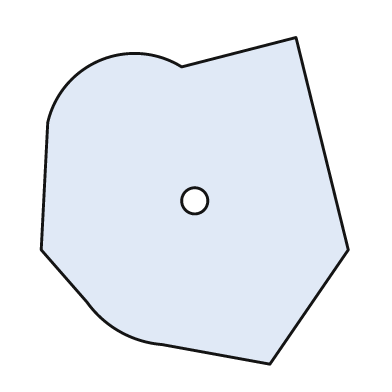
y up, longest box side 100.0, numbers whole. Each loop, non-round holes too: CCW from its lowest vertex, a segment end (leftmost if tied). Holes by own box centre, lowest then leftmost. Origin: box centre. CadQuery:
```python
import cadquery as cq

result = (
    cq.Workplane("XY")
    .moveTo(23.0, -50.0)
    .lineTo(47.0, -15.0)
    .lineTo(31.0, 50.0)
    .lineTo(-4.0, 41.0)
    .threePointArc((-29.0, 43.0), (-45.0, 24.0))
    .lineTo(-47.0, -15.0)
    .lineTo(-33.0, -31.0)
    .threePointArc((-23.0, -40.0), (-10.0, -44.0))
    .close()
    .moveTo(0.0, 0.0)
    .circle(4.0)
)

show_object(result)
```